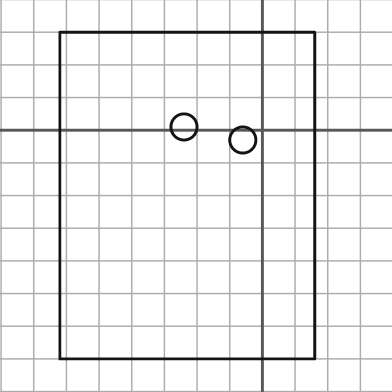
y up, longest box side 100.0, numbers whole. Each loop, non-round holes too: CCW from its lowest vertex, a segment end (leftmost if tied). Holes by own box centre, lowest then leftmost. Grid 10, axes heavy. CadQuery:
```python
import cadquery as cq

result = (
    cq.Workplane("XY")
    .moveTo(-62.0, -70.0)
    .lineTo(16.0, -70.0)
    .lineTo(16.0, 30.0)
    .lineTo(-62.0, 30.0)
    .close()
    .moveTo(-6.0, -3.0)
    .circle(4.0)
    .moveTo(-24.0, 1.0)
    .circle(4.0)
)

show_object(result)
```